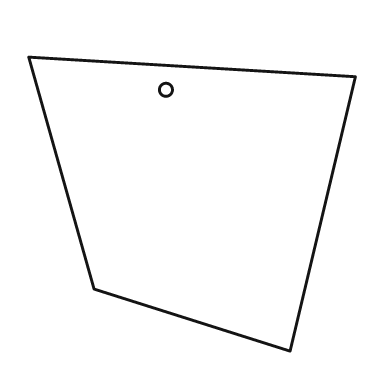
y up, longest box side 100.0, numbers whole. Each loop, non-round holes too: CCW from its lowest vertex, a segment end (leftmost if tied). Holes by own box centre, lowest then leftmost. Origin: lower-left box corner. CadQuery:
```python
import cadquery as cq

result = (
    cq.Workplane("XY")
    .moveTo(80.0, 0.0)
    .lineTo(100.0, 84.0)
    .lineTo(0.0, 90.0)
    .lineTo(20.0, 19.0)
    .close()
    .moveTo(42.0, 80.0)
    .circle(2.0)
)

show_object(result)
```